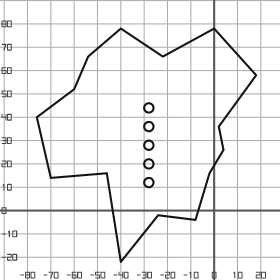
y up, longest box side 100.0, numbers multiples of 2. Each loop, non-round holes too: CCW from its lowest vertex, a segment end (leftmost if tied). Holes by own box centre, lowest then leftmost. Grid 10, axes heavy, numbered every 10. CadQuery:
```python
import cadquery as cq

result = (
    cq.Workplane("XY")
    .moveTo(-40.0, -22.0)
    .lineTo(-24.0, -2.0)
    .lineTo(-8.0, -4.0)
    .lineTo(-2.0, 16.0)
    .lineTo(4.0, 26.0)
    .lineTo(2.0, 36.0)
    .lineTo(18.0, 58.0)
    .lineTo(0.0, 78.0)
    .lineTo(-22.0, 66.0)
    .lineTo(-40.0, 78.0)
    .lineTo(-54.0, 66.0)
    .lineTo(-60.0, 52.0)
    .lineTo(-76.0, 40.0)
    .lineTo(-70.0, 14.0)
    .lineTo(-46.0, 16.0)
    .close()
    .moveTo(-28.0, 12.0)
    .circle(2.0)
    .moveTo(-28.0, 20.0)
    .circle(2.0)
    .moveTo(-28.0, 28.0)
    .circle(2.0)
    .moveTo(-28.0, 36.0)
    .circle(2.0)
    .moveTo(-28.0, 44.0)
    .circle(2.0)
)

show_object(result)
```